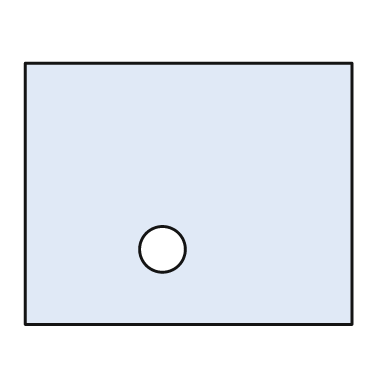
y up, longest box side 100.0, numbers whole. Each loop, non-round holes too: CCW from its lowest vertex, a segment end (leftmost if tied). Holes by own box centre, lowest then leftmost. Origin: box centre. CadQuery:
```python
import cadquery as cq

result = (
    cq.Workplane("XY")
    .moveTo(-50.0, -40.0)
    .lineTo(50.0, -40.0)
    .lineTo(50.0, 40.0)
    .lineTo(-50.0, 40.0)
    .close()
    .moveTo(-8.0, -17.0)
    .circle(7.0)
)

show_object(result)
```